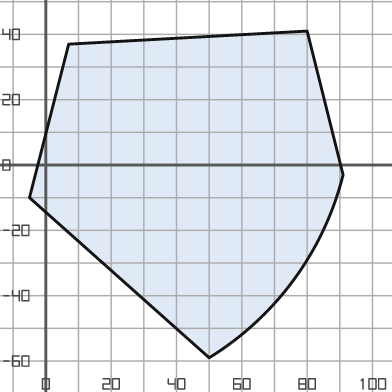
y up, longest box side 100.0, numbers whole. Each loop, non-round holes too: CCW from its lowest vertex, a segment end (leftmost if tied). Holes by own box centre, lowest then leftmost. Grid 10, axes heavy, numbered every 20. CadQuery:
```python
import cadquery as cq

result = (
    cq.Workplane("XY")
    .moveTo(50.0, -59.0)
    .threePointArc((76.0, -35.0), (91.0, -3.0))
    .lineTo(80.0, 41.0)
    .lineTo(7.0, 37.0)
    .lineTo(-5.0, -10.0)
    .close()
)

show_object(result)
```